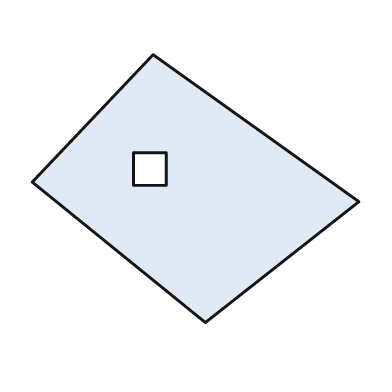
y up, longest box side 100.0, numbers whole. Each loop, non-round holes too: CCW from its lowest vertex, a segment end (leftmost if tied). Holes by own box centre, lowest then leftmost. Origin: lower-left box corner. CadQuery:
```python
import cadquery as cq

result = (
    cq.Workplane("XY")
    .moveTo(53.0, 0.0)
    .lineTo(100.0, 37.0)
    .lineTo(37.0, 82.0)
    .lineTo(0.0, 43.0)
    .close()
    .moveTo(31.0, 42.0)
    .lineTo(41.0, 42.0)
    .lineTo(41.0, 52.0)
    .lineTo(31.0, 52.0)
    .close()
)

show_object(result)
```